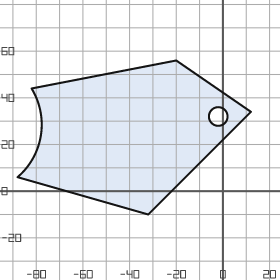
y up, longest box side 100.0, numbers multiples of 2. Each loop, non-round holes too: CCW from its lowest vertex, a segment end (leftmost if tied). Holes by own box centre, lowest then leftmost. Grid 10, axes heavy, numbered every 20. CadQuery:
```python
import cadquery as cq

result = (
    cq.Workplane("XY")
    .moveTo(-32.0, -10.0)
    .lineTo(12.0, 34.0)
    .lineTo(-20.0, 56.0)
    .lineTo(-82.0, 44.0)
    .threePointArc((-78.0, 24.0), (-88.0, 6.0))
    .close()
    .moveTo(-2.0, 32.0)
    .circle(4.0)
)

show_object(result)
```